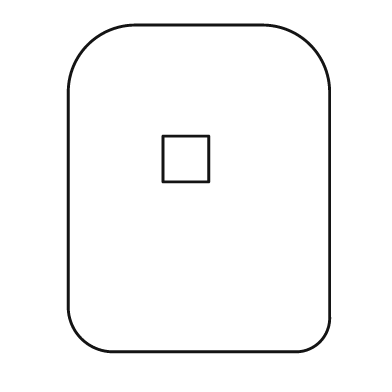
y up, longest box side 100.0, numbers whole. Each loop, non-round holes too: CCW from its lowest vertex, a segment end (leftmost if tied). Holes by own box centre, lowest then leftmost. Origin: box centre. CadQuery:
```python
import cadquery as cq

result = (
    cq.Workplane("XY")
    .moveTo(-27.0, -50.0)
    .lineTo(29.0, -50.0)
    .threePointArc((37.0, -47.0), (40.0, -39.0))
    .lineTo(40.0, 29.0)
    .threePointArc((34.0, 44.0), (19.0, 50.0))
    .lineTo(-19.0, 50.0)
    .threePointArc((-34.0, 44.0), (-40.0, 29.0))
    .lineTo(-40.0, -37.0)
    .threePointArc((-36.0, -46.0), (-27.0, -50.0))
    .close()
    .moveTo(-11.0, 2.0)
    .lineTo(3.0, 2.0)
    .lineTo(3.0, 16.0)
    .lineTo(-11.0, 16.0)
    .close()
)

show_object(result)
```